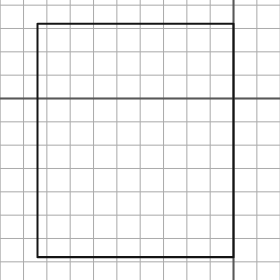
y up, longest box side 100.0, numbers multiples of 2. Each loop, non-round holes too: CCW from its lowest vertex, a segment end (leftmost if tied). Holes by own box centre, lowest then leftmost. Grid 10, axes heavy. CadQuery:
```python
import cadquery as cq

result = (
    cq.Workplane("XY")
    .moveTo(-84.0, -68.0)
    .lineTo(0.0, -68.0)
    .lineTo(0.0, 32.0)
    .lineTo(-84.0, 32.0)
    .close()
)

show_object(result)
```